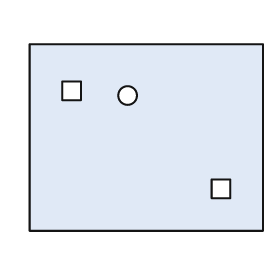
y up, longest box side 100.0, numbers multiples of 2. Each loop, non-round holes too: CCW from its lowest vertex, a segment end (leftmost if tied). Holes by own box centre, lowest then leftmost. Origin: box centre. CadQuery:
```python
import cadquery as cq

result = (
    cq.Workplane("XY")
    .moveTo(-50.0, -40.0)
    .lineTo(50.0, -40.0)
    .lineTo(50.0, 40.0)
    .lineTo(-50.0, 40.0)
    .close()
    .moveTo(28.0, -26.0)
    .lineTo(36.0, -26.0)
    .lineTo(36.0, -18.0)
    .lineTo(28.0, -18.0)
    .close()
    .moveTo(-8.0, 18.0)
    .circle(4.0)
    .moveTo(-36.0, 16.0)
    .lineTo(-28.0, 16.0)
    .lineTo(-28.0, 24.0)
    .lineTo(-36.0, 24.0)
    .close()
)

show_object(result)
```